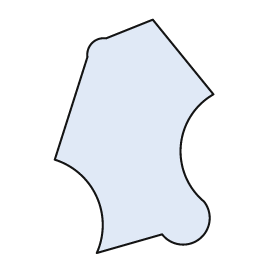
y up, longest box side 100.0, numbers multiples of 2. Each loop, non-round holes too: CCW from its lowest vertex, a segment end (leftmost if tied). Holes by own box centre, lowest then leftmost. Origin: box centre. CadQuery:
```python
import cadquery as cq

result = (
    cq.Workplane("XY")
    .moveTo(-16.0, -50.0)
    .lineTo(12.0, -42.0)
    .threePointArc((28.0, -44.0), (30.0, -28.0))
    .threePointArc((20.0, -4.0), (34.0, 18.0))
    .lineTo(8.0, 50.0)
    .lineTo(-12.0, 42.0)
    .threePointArc((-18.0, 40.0), (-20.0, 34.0))
    .lineTo(-34.0, -10.0)
    .threePointArc((-16.0, -26.0), (-16.0, -50.0))
    .close()
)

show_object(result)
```